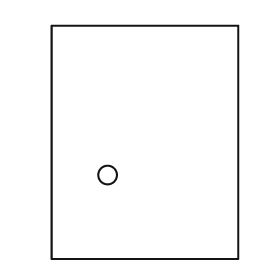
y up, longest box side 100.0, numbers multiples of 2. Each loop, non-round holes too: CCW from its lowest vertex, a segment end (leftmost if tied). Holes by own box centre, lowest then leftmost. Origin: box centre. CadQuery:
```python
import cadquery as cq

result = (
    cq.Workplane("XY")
    .moveTo(-40.0, -50.0)
    .lineTo(40.0, -50.0)
    .lineTo(40.0, 50.0)
    .lineTo(-40.0, 50.0)
    .close()
    .moveTo(-16.0, -14.0)
    .circle(4.0)
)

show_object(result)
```